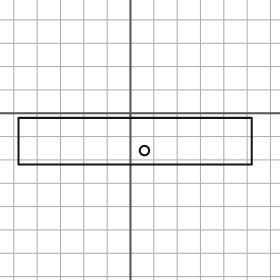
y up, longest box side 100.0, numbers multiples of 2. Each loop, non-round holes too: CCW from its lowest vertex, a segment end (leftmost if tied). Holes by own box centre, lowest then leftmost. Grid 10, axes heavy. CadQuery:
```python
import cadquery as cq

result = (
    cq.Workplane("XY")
    .moveTo(-48.0, -22.0)
    .lineTo(52.0, -22.0)
    .lineTo(52.0, -2.0)
    .lineTo(-48.0, -2.0)
    .close()
    .moveTo(6.0, -16.0)
    .circle(2.0)
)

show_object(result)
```